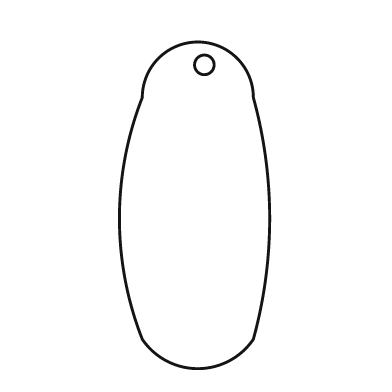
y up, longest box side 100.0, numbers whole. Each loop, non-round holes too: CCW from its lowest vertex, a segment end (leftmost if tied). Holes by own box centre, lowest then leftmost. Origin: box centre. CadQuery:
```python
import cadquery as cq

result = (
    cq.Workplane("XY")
    .moveTo(-16.0, -41.0)
    .threePointArc((1.0, -50.0), (18.0, -41.0))
    .threePointArc((23.0, -4.0), (18.0, 33.0))
    .threePointArc((1.0, 50.0), (-16.0, 33.0))
    .threePointArc((-23.0, -4.0), (-16.0, -41.0))
    .close()
    .moveTo(3.0, 43.0)
    .circle(3.0)
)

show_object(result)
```